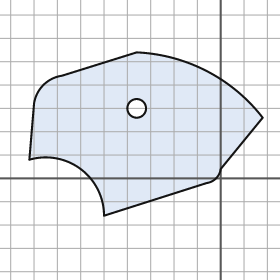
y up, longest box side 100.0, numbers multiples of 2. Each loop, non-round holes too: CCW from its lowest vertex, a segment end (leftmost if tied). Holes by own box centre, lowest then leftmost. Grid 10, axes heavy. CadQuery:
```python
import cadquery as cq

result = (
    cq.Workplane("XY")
    .moveTo(-50.0, -16.0)
    .lineTo(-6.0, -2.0)
    .threePointArc((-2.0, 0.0), (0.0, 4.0))
    .lineTo(18.0, 26.0)
    .threePointArc((-6.0, 46.0), (-36.0, 54.0))
    .lineTo(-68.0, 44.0)
    .threePointArc((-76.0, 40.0), (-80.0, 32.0))
    .lineTo(-82.0, 8.0)
    .threePointArc((-60.0, 4.0), (-50.0, -16.0))
    .close()
    .moveTo(-36.0, 30.0)
    .circle(4.0)
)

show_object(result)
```